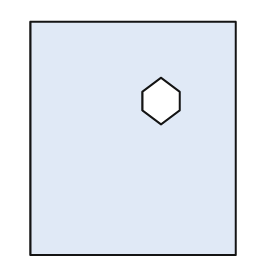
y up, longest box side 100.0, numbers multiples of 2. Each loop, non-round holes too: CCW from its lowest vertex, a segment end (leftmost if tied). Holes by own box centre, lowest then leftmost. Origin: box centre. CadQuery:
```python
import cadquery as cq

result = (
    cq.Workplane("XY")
    .moveTo(-44.0, -50.0)
    .lineTo(44.0, -50.0)
    .lineTo(44.0, 50.0)
    .lineTo(-44.0, 50.0)
    .close()
    .moveTo(12.0, 6.0)
    .lineTo(20.0, 12.0)
    .lineTo(20.0, 20.0)
    .lineTo(12.0, 26.0)
    .lineTo(4.0, 20.0)
    .lineTo(4.0, 12.0)
    .close()
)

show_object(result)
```